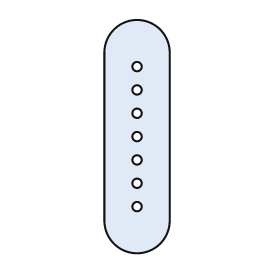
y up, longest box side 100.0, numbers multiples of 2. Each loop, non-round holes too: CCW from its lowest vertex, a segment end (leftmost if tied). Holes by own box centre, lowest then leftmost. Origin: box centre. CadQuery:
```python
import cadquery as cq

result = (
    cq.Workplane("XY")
    .moveTo(-14.0, -36.0)
    .threePointArc((0.0, -50.0), (14.0, -36.0))
    .lineTo(14.0, 36.0)
    .threePointArc((0.0, 50.0), (-14.0, 36.0))
    .close()
    .moveTo(0.0, -30.0)
    .circle(2.0)
    .moveTo(0.0, -20.0)
    .circle(2.0)
    .moveTo(0.0, -10.0)
    .circle(2.0)
    .moveTo(0.0, 0.0)
    .circle(2.0)
    .moveTo(0.0, 10.0)
    .circle(2.0)
    .moveTo(0.0, 20.0)
    .circle(2.0)
    .moveTo(0.0, 30.0)
    .circle(2.0)
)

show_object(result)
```